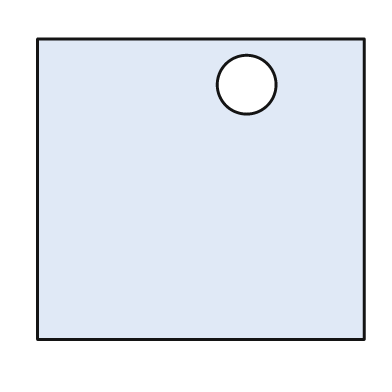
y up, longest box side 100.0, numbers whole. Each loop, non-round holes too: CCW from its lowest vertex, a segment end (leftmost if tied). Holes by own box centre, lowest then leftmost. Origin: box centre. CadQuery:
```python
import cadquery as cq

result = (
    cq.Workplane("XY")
    .moveTo(-50.0, -46.0)
    .lineTo(50.0, -46.0)
    .lineTo(50.0, 46.0)
    .lineTo(-50.0, 46.0)
    .close()
    .moveTo(14.0, 32.0)
    .circle(9.0)
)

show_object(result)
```